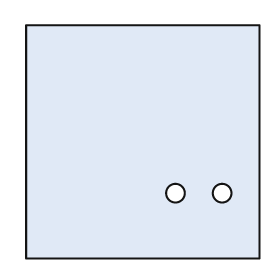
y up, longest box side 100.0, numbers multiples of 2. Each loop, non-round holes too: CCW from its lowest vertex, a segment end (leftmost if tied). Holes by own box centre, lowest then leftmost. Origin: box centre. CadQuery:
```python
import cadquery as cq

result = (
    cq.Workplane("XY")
    .moveTo(-50.0, -50.0)
    .lineTo(50.0, -50.0)
    .lineTo(50.0, 50.0)
    .lineTo(-50.0, 50.0)
    .close()
    .moveTo(14.0, -22.0)
    .circle(4.0)
    .moveTo(34.0, -22.0)
    .circle(4.0)
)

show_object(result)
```